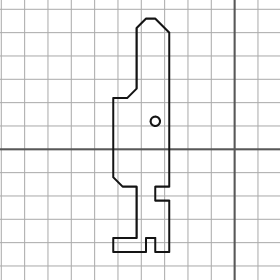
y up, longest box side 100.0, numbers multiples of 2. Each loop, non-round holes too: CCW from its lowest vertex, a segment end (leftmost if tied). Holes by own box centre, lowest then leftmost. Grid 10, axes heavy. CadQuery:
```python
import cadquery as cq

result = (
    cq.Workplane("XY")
    .moveTo(-52.0, -44.0)
    .lineTo(-38.0, -44.0)
    .lineTo(-38.0, -38.0)
    .lineTo(-34.0, -38.0)
    .lineTo(-34.0, -44.0)
    .lineTo(-28.0, -44.0)
    .lineTo(-28.0, -22.0)
    .lineTo(-34.0, -22.0)
    .lineTo(-34.0, -16.0)
    .lineTo(-28.0, -16.0)
    .lineTo(-28.0, 50.0)
    .lineTo(-34.0, 56.0)
    .lineTo(-38.0, 56.0)
    .lineTo(-42.0, 52.0)
    .lineTo(-42.0, 26.0)
    .lineTo(-46.0, 22.0)
    .lineTo(-52.0, 22.0)
    .lineTo(-52.0, -12.0)
    .lineTo(-48.0, -16.0)
    .lineTo(-42.0, -16.0)
    .lineTo(-42.0, -38.0)
    .lineTo(-52.0, -38.0)
    .close()
    .moveTo(-34.0, 12.0)
    .circle(2.0)
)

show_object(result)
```